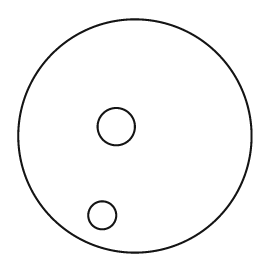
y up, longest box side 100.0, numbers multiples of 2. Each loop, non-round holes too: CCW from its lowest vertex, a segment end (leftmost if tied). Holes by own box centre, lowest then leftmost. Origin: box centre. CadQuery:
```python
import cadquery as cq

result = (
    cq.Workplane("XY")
    .moveTo(0.0, 0.0)
    .circle(50.0)
    .moveTo(-14.0, -34.0)
    .circle(6.0)
    .moveTo(-8.0, 4.0)
    .circle(8.0)
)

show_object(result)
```